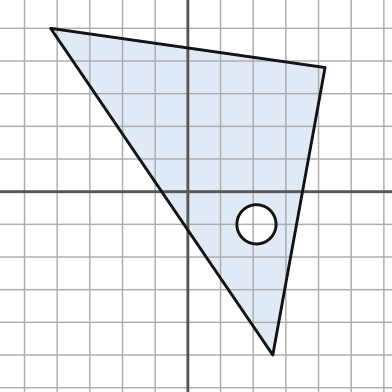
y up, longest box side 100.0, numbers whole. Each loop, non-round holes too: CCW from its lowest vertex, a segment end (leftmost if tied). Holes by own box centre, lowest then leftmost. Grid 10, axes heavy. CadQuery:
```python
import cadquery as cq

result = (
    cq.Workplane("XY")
    .moveTo(26.0, -50.0)
    .lineTo(42.0, 38.0)
    .lineTo(-42.0, 50.0)
    .close()
    .moveTo(21.0, -10.0)
    .circle(6.0)
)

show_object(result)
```